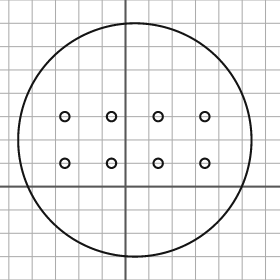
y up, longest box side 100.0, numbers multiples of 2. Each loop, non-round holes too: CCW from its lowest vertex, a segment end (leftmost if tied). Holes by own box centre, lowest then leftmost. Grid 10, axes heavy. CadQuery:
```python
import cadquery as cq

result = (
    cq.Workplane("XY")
    .moveTo(4.0, 20.0)
    .circle(50.0)
    .moveTo(-26.0, 10.0)
    .circle(2.0)
    .moveTo(-6.0, 10.0)
    .circle(2.0)
    .moveTo(14.0, 10.0)
    .circle(2.0)
    .moveTo(34.0, 10.0)
    .circle(2.0)
    .moveTo(-26.0, 30.0)
    .circle(2.0)
    .moveTo(-6.0, 30.0)
    .circle(2.0)
    .moveTo(14.0, 30.0)
    .circle(2.0)
    .moveTo(34.0, 30.0)
    .circle(2.0)
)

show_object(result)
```